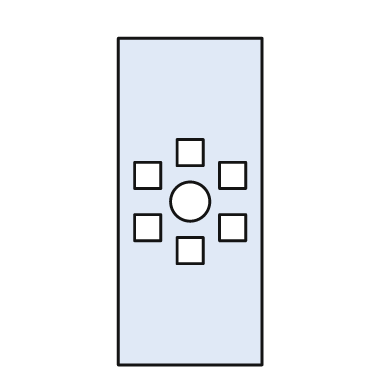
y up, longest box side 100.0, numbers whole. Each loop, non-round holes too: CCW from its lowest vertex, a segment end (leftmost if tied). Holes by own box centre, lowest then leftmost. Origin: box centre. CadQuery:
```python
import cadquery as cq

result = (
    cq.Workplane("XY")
    .moveTo(-22.0, -50.0)
    .lineTo(22.0, -50.0)
    .lineTo(22.0, 50.0)
    .lineTo(-22.0, 50.0)
    .close()
    .moveTo(-4.0, -19.0)
    .lineTo(4.0, -19.0)
    .lineTo(4.0, -11.0)
    .lineTo(-4.0, -11.0)
    .close()
    .moveTo(-17.0, -12.0)
    .lineTo(-9.0, -12.0)
    .lineTo(-9.0, -4.0)
    .lineTo(-17.0, -4.0)
    .close()
    .moveTo(9.0, -12.0)
    .lineTo(17.0, -12.0)
    .lineTo(17.0, -4.0)
    .lineTo(9.0, -4.0)
    .close()
    .moveTo(0.0, 0.0)
    .circle(6.0)
    .moveTo(-17.0, 4.0)
    .lineTo(-9.0, 4.0)
    .lineTo(-9.0, 12.0)
    .lineTo(-17.0, 12.0)
    .close()
    .moveTo(9.0, 4.0)
    .lineTo(17.0, 4.0)
    .lineTo(17.0, 12.0)
    .lineTo(9.0, 12.0)
    .close()
    .moveTo(-4.0, 11.0)
    .lineTo(4.0, 11.0)
    .lineTo(4.0, 19.0)
    .lineTo(-4.0, 19.0)
    .close()
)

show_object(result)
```